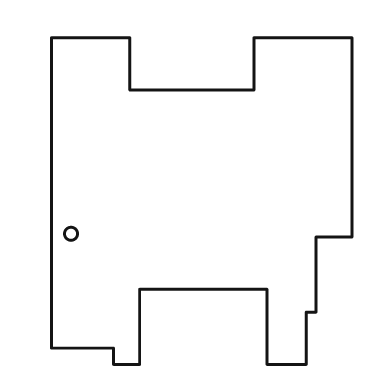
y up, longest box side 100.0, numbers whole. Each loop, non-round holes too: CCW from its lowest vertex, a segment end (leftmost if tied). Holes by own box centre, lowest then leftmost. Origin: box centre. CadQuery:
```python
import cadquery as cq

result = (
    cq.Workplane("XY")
    .moveTo(-27.0, -50.0)
    .lineTo(-19.0, -50.0)
    .lineTo(-19.0, -27.0)
    .lineTo(20.0, -27.0)
    .lineTo(20.0, -50.0)
    .lineTo(32.0, -50.0)
    .lineTo(32.0, -34.0)
    .lineTo(35.0, -34.0)
    .lineTo(35.0, -11.0)
    .lineTo(46.0, -11.0)
    .lineTo(46.0, 50.0)
    .lineTo(16.0, 50.0)
    .lineTo(16.0, 34.0)
    .lineTo(-22.0, 34.0)
    .lineTo(-22.0, 50.0)
    .lineTo(-46.0, 50.0)
    .lineTo(-46.0, -45.0)
    .lineTo(-27.0, -45.0)
    .close()
    .moveTo(-40.0, -10.0)
    .circle(2.0)
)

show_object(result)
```